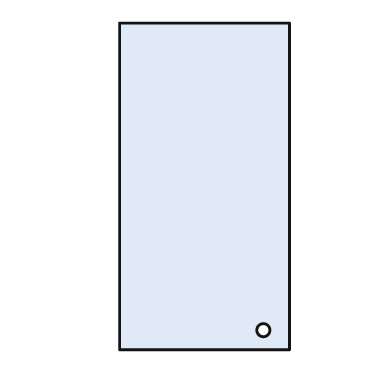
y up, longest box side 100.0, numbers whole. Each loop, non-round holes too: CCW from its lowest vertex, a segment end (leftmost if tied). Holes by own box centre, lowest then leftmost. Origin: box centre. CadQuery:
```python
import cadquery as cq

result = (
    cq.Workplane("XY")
    .moveTo(-26.0, -50.0)
    .lineTo(26.0, -50.0)
    .lineTo(26.0, 50.0)
    .lineTo(-26.0, 50.0)
    .close()
    .moveTo(18.0, -44.0)
    .circle(2.0)
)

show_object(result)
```